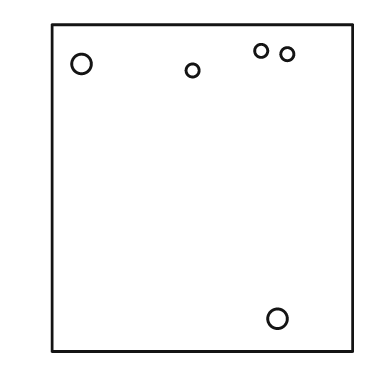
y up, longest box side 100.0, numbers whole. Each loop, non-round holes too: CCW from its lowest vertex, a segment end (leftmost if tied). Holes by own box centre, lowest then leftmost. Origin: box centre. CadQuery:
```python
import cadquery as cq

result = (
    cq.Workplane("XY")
    .moveTo(-46.0, -50.0)
    .lineTo(46.0, -50.0)
    .lineTo(46.0, 50.0)
    .lineTo(-46.0, 50.0)
    .close()
    .moveTo(23.0, -40.0)
    .circle(3.0)
    .moveTo(-3.0, 36.0)
    .circle(2.0)
    .moveTo(-37.0, 38.0)
    .circle(3.0)
    .moveTo(26.0, 41.0)
    .circle(2.0)
    .moveTo(18.0, 42.0)
    .circle(2.0)
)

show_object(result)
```